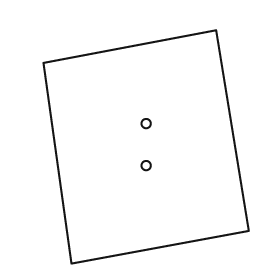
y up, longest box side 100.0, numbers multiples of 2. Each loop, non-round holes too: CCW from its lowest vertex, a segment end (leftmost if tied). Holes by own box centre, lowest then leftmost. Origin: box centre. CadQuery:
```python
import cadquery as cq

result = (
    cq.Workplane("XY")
    .moveTo(-32.0, -50.0)
    .lineTo(44.0, -36.0)
    .lineTo(30.0, 50.0)
    .lineTo(-44.0, 36.0)
    .close()
    .moveTo(0.0, -8.0)
    .circle(2.0)
    .moveTo(0.0, 10.0)
    .circle(2.0)
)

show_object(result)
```